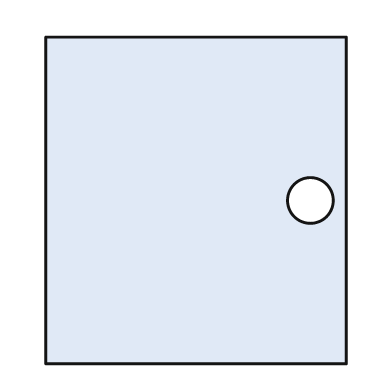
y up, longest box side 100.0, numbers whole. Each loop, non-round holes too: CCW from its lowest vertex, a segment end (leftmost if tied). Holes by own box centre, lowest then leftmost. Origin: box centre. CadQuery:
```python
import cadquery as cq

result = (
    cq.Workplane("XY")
    .moveTo(-46.0, -50.0)
    .lineTo(46.0, -50.0)
    .lineTo(46.0, 50.0)
    .lineTo(-46.0, 50.0)
    .close()
    .moveTo(35.0, 0.0)
    .circle(7.0)
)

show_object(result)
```